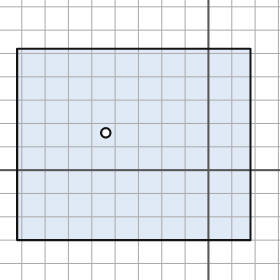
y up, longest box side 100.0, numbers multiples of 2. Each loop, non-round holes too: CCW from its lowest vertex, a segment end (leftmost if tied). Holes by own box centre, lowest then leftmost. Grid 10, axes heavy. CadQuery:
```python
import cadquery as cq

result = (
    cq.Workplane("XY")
    .moveTo(-82.0, -30.0)
    .lineTo(18.0, -30.0)
    .lineTo(18.0, 52.0)
    .lineTo(-82.0, 52.0)
    .close()
    .moveTo(-44.0, 16.0)
    .circle(2.0)
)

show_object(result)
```